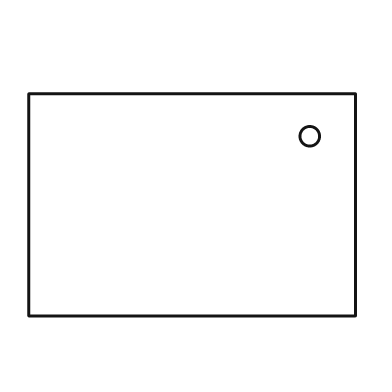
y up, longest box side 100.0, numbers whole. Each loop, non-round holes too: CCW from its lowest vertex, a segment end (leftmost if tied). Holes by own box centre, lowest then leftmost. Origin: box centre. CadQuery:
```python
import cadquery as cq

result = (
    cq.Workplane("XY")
    .moveTo(-50.0, -34.0)
    .lineTo(50.0, -34.0)
    .lineTo(50.0, 34.0)
    .lineTo(-50.0, 34.0)
    .close()
    .moveTo(36.0, 21.0)
    .circle(3.0)
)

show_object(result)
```